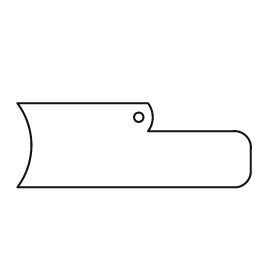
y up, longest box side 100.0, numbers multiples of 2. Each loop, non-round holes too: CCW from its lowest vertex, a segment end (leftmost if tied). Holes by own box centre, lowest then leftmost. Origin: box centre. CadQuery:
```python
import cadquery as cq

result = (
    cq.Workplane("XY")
    .moveTo(-50.0, -18.0)
    .lineTo(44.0, -18.0)
    .threePointArc((48.0, -16.0), (50.0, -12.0))
    .lineTo(50.0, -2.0)
    .threePointArc((48.0, 4.0), (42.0, 6.0))
    .lineTo(6.0, 6.0)
    .threePointArc((8.0, 12.0), (6.0, 18.0))
    .lineTo(-50.0, 18.0)
    .threePointArc((-44.0, 0.0), (-50.0, -18.0))
    .close()
    .moveTo(2.0, 12.0)
    .circle(2.0)
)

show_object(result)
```